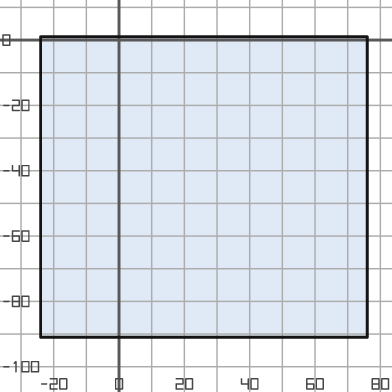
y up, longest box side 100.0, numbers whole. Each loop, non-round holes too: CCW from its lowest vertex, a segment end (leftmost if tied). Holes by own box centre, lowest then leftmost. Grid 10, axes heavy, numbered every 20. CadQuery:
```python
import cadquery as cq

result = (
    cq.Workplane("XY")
    .moveTo(-24.0, -91.0)
    .lineTo(76.0, -91.0)
    .lineTo(76.0, 1.0)
    .lineTo(-24.0, 1.0)
    .close()
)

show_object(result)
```